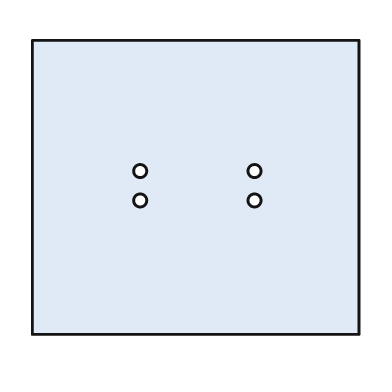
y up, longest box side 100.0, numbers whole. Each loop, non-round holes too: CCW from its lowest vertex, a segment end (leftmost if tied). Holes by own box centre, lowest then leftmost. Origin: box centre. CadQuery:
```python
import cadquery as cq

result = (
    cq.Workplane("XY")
    .moveTo(-50.0, -45.0)
    .lineTo(50.0, -45.0)
    .lineTo(50.0, 45.0)
    .lineTo(-50.0, 45.0)
    .close()
    .moveTo(-17.0, -4.0)
    .circle(2.0)
    .moveTo(18.0, -4.0)
    .circle(2.0)
    .moveTo(-17.0, 5.0)
    .circle(2.0)
    .moveTo(18.0, 5.0)
    .circle(2.0)
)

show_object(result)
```